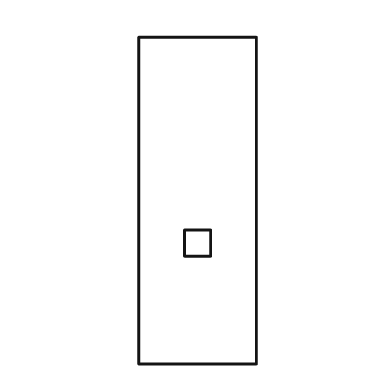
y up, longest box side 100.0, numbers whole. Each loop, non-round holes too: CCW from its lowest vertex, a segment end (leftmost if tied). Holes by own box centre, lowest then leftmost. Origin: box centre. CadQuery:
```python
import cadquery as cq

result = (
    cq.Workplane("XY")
    .moveTo(-18.0, -50.0)
    .lineTo(18.0, -50.0)
    .lineTo(18.0, 50.0)
    .lineTo(-18.0, 50.0)
    .close()
    .moveTo(-4.0, -17.0)
    .lineTo(4.0, -17.0)
    .lineTo(4.0, -9.0)
    .lineTo(-4.0, -9.0)
    .close()
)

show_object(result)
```